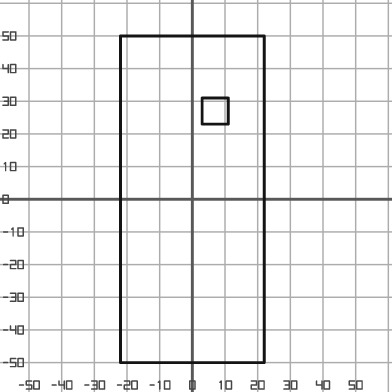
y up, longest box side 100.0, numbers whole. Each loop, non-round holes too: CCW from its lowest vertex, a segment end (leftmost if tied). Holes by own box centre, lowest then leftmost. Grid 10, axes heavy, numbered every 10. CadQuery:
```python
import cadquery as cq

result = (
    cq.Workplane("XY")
    .moveTo(-22.0, -50.0)
    .lineTo(22.0, -50.0)
    .lineTo(22.0, 50.0)
    .lineTo(-22.0, 50.0)
    .close()
    .moveTo(3.0, 23.0)
    .lineTo(11.0, 23.0)
    .lineTo(11.0, 31.0)
    .lineTo(3.0, 31.0)
    .close()
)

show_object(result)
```